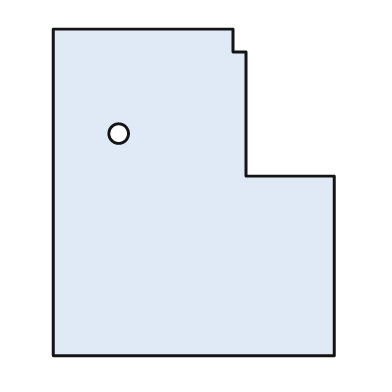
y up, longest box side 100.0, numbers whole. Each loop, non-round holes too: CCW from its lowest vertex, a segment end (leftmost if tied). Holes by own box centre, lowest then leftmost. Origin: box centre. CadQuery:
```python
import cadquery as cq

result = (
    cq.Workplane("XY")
    .moveTo(-43.0, -50.0)
    .lineTo(43.0, -50.0)
    .lineTo(43.0, 5.0)
    .lineTo(16.0, 5.0)
    .lineTo(16.0, 43.0)
    .lineTo(12.0, 43.0)
    .lineTo(12.0, 50.0)
    .lineTo(-43.0, 50.0)
    .close()
    .moveTo(-23.0, 18.0)
    .circle(3.0)
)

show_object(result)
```